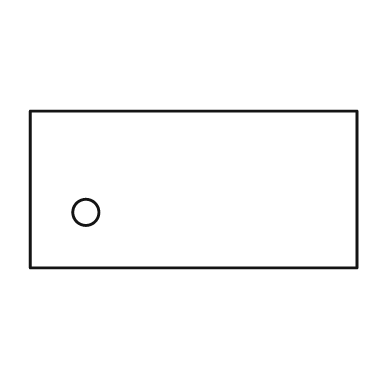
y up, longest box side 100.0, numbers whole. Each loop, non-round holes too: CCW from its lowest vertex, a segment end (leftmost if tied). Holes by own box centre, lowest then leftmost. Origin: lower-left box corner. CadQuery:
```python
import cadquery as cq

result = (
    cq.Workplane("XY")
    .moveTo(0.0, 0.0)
    .lineTo(100.0, 0.0)
    .lineTo(100.0, 48.0)
    .lineTo(0.0, 48.0)
    .close()
    .moveTo(17.0, 17.0)
    .circle(4.0)
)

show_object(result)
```